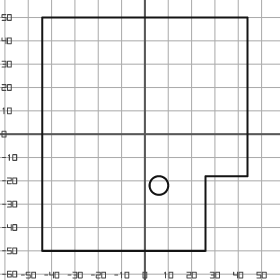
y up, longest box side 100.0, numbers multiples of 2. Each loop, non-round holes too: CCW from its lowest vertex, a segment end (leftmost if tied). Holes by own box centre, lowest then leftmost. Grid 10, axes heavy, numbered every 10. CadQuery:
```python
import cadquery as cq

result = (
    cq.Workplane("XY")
    .moveTo(-44.0, -50.0)
    .lineTo(26.0, -50.0)
    .lineTo(26.0, -18.0)
    .lineTo(44.0, -18.0)
    .lineTo(44.0, 50.0)
    .lineTo(-44.0, 50.0)
    .close()
    .moveTo(6.0, -22.0)
    .circle(4.0)
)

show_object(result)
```